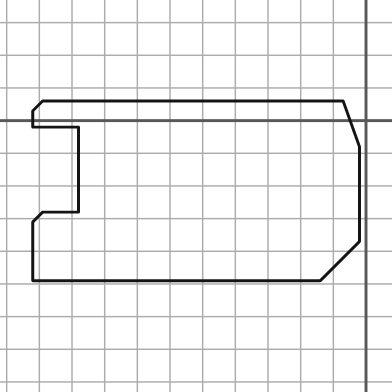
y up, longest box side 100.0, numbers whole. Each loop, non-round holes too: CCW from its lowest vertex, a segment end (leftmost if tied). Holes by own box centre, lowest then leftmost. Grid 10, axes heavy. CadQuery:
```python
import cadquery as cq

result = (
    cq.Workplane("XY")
    .moveTo(-102.0, -49.0)
    .lineTo(-14.0, -49.0)
    .lineTo(-2.0, -37.0)
    .lineTo(-2.0, -8.0)
    .lineTo(-7.0, 6.0)
    .lineTo(-99.0, 6.0)
    .lineTo(-102.0, 3.0)
    .lineTo(-102.0, -2.0)
    .lineTo(-88.0, -2.0)
    .lineTo(-88.0, -28.0)
    .lineTo(-99.0, -28.0)
    .lineTo(-102.0, -31.0)
    .close()
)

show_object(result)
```